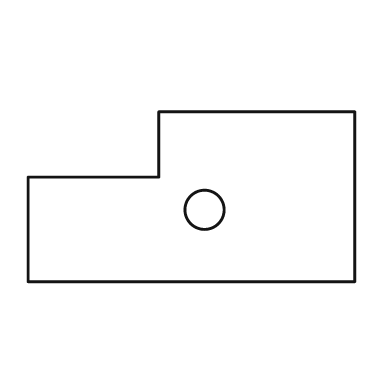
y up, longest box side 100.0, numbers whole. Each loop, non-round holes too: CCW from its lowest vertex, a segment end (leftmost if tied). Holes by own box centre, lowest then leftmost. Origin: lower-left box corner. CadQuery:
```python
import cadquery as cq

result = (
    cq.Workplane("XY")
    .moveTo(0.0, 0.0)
    .lineTo(100.0, 0.0)
    .lineTo(100.0, 52.0)
    .lineTo(40.0, 52.0)
    .lineTo(40.0, 32.0)
    .lineTo(0.0, 32.0)
    .close()
    .moveTo(54.0, 22.0)
    .circle(6.0)
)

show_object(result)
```